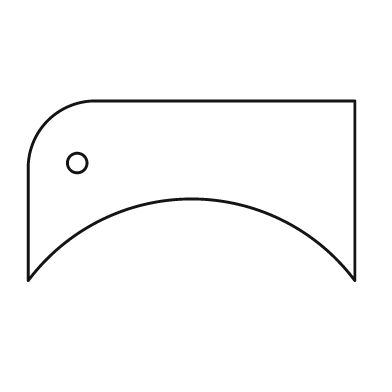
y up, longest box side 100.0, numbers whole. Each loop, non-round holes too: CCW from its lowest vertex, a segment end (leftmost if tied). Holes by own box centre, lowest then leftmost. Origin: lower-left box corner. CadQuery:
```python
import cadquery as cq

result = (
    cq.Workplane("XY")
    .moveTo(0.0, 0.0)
    .threePointArc((50.0, 25.0), (100.0, 0.0))
    .lineTo(100.0, 55.0)
    .lineTo(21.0, 55.0)
    .threePointArc((6.0, 49.0), (0.0, 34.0))
    .close()
    .moveTo(15.0, 36.0)
    .circle(3.0)
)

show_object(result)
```